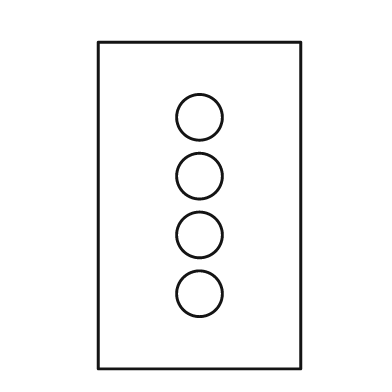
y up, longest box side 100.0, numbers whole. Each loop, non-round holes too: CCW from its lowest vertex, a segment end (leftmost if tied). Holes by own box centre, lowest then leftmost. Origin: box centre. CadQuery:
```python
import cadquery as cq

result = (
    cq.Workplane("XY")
    .moveTo(-31.0, -50.0)
    .lineTo(31.0, -50.0)
    .lineTo(31.0, 50.0)
    .lineTo(-31.0, 50.0)
    .close()
    .moveTo(0.0, -27.0)
    .circle(7.0)
    .moveTo(0.0, -9.0)
    .circle(7.0)
    .moveTo(0.0, 9.0)
    .circle(7.0)
    .moveTo(0.0, 27.0)
    .circle(7.0)
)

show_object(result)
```